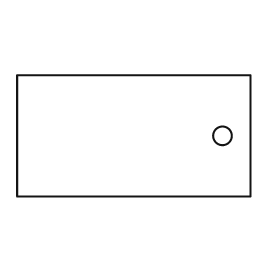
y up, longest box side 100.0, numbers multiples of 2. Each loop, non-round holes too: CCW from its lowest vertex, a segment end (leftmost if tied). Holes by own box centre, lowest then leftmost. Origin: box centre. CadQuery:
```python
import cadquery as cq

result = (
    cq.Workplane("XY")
    .moveTo(-50.0, -26.0)
    .lineTo(50.0, -26.0)
    .lineTo(50.0, 26.0)
    .lineTo(-50.0, 26.0)
    .close()
    .moveTo(38.0, 0.0)
    .circle(4.0)
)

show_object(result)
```